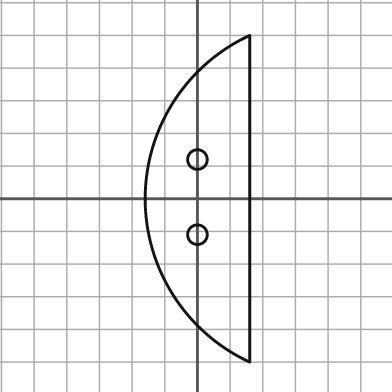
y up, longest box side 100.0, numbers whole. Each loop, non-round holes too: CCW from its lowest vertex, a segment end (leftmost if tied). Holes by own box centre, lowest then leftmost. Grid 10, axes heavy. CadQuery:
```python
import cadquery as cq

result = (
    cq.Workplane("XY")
    .moveTo(16.0, -50.0)
    .lineTo(16.0, 50.0)
    .threePointArc((-16.0, 0.0), (16.0, -50.0))
    .close()
    .moveTo(0.0, -11.0)
    .circle(3.0)
    .moveTo(0.0, 12.0)
    .circle(3.0)
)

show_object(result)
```